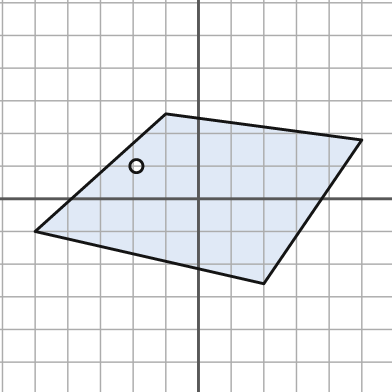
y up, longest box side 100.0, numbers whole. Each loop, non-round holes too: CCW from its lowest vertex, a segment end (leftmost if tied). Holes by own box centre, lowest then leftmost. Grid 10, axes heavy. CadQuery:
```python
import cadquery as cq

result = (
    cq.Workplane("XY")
    .moveTo(20.0, -26.0)
    .lineTo(50.0, 18.0)
    .lineTo(-10.0, 26.0)
    .lineTo(-50.0, -10.0)
    .close()
    .moveTo(-19.0, 10.0)
    .circle(2.0)
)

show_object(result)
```